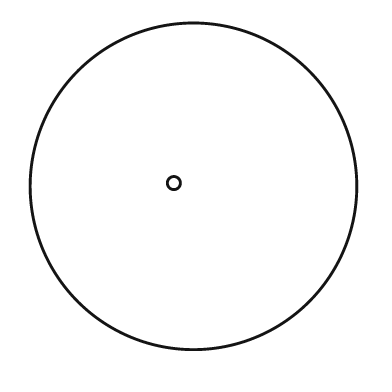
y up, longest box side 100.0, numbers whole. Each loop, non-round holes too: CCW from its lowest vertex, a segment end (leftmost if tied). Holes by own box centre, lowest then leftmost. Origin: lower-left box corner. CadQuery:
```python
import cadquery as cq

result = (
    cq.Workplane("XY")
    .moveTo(50.0, 50.0)
    .circle(50.0)
    .moveTo(44.0, 51.0)
    .circle(2.0)
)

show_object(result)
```